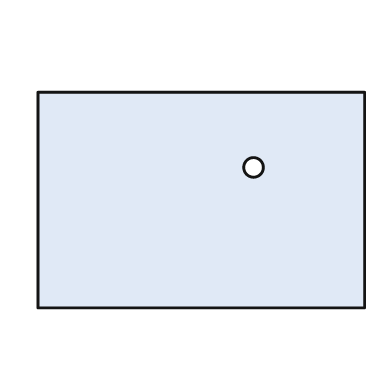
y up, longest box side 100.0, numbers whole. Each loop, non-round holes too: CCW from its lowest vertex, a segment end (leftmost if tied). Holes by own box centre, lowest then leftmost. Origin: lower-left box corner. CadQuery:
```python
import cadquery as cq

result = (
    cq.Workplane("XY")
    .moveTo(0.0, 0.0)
    .lineTo(100.0, 0.0)
    .lineTo(100.0, 66.0)
    .lineTo(0.0, 66.0)
    .close()
    .moveTo(66.0, 43.0)
    .circle(3.0)
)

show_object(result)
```